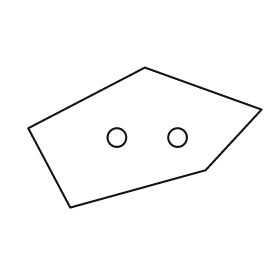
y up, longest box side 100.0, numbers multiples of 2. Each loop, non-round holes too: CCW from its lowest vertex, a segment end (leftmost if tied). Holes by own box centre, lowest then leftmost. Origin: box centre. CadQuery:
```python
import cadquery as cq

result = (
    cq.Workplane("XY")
    .moveTo(-32.0, -30.0)
    .lineTo(26.0, -14.0)
    .lineTo(50.0, 12.0)
    .lineTo(0.0, 30.0)
    .lineTo(-50.0, 4.0)
    .close()
    .moveTo(-12.0, 0.0)
    .circle(4.0)
    .moveTo(14.0, 0.0)
    .circle(4.0)
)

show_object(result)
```